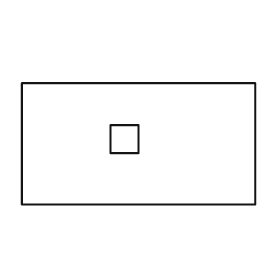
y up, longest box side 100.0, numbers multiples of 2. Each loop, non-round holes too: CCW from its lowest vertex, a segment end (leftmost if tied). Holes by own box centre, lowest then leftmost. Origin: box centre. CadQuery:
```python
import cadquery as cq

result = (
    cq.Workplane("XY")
    .moveTo(-50.0, -26.0)
    .lineTo(50.0, -26.0)
    .lineTo(50.0, 26.0)
    .lineTo(-50.0, 26.0)
    .close()
    .moveTo(-12.0, -4.0)
    .lineTo(0.0, -4.0)
    .lineTo(0.0, 8.0)
    .lineTo(-12.0, 8.0)
    .close()
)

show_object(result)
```